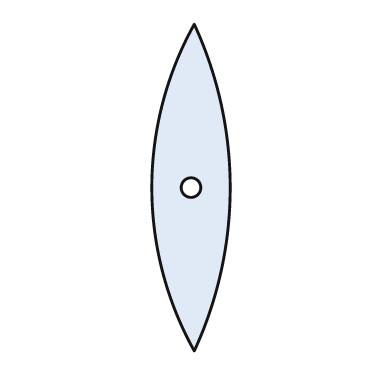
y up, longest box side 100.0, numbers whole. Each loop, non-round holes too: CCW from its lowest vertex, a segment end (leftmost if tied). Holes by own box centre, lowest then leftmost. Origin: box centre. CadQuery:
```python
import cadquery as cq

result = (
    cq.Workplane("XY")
    .moveTo(1.0, -50.0)
    .threePointArc((12.0, 0.0), (1.0, 50.0))
    .threePointArc((-12.0, 0.0), (1.0, -50.0))
    .close()
    .moveTo(0.0, 0.0)
    .circle(3.0)
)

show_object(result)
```